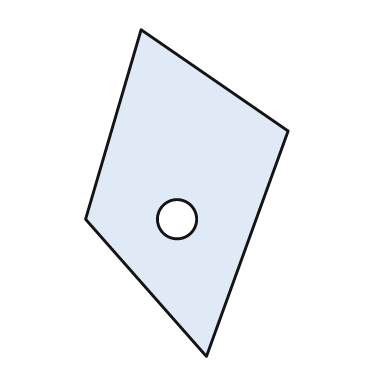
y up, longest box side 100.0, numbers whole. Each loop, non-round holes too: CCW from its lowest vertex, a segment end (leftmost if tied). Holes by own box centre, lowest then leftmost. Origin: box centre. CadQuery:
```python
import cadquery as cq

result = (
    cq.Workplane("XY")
    .moveTo(6.0, -50.0)
    .lineTo(31.0, 19.0)
    .lineTo(-14.0, 50.0)
    .lineTo(-31.0, -8.0)
    .close()
    .moveTo(-3.0, -8.0)
    .circle(6.0)
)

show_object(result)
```